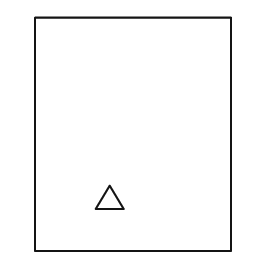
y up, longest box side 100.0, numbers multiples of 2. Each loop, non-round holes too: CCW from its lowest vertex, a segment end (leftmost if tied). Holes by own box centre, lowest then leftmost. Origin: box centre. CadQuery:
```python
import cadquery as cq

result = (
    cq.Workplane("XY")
    .moveTo(-42.0, -50.0)
    .lineTo(42.0, -50.0)
    .lineTo(42.0, 50.0)
    .lineTo(-42.0, 50.0)
    .close()
    .moveTo(-16.0, -32.0)
    .lineTo(-4.0, -32.0)
    .lineTo(-10.0, -22.0)
    .close()
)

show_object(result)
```